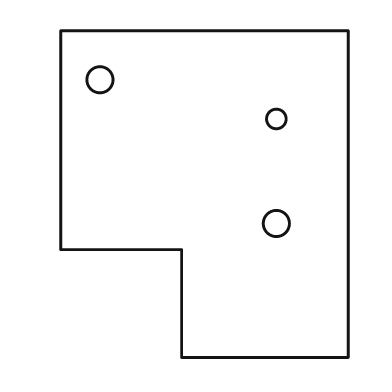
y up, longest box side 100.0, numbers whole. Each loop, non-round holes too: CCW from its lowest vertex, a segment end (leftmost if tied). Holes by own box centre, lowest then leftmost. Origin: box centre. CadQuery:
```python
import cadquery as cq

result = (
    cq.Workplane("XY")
    .moveTo(-7.0, -50.0)
    .lineTo(44.0, -50.0)
    .lineTo(44.0, 50.0)
    .lineTo(-44.0, 50.0)
    .lineTo(-44.0, -17.0)
    .lineTo(-7.0, -17.0)
    .close()
    .moveTo(22.0, -9.0)
    .circle(4.0)
    .moveTo(22.0, 23.0)
    .circle(3.0)
    .moveTo(-32.0, 35.0)
    .circle(4.0)
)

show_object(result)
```